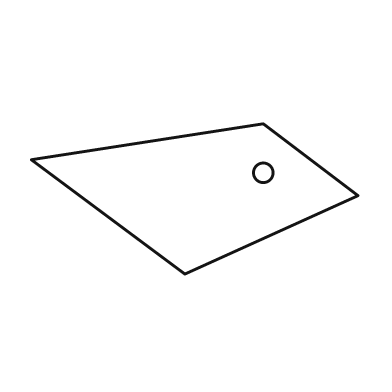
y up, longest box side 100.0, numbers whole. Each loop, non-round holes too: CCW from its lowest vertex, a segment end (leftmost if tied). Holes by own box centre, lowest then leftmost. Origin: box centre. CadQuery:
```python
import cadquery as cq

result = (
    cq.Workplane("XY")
    .moveTo(-3.0, -23.0)
    .lineTo(50.0, 1.0)
    .lineTo(21.0, 23.0)
    .lineTo(-50.0, 12.0)
    .close()
    .moveTo(21.0, 8.0)
    .circle(3.0)
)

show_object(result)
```